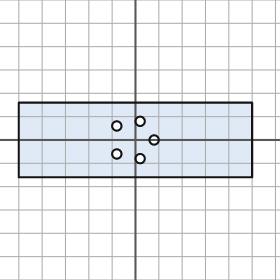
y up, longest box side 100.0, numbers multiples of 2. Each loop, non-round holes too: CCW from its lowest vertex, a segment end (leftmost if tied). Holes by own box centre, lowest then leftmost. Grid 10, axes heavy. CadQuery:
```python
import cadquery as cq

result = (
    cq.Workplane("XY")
    .moveTo(-50.0, -16.0)
    .lineTo(50.0, -16.0)
    .lineTo(50.0, 16.0)
    .lineTo(-50.0, 16.0)
    .close()
    .moveTo(2.0, -8.0)
    .circle(2.0)
    .moveTo(-8.0, -6.0)
    .circle(2.0)
    .moveTo(8.0, 0.0)
    .circle(2.0)
    .moveTo(-8.0, 6.0)
    .circle(2.0)
    .moveTo(2.0, 8.0)
    .circle(2.0)
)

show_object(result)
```